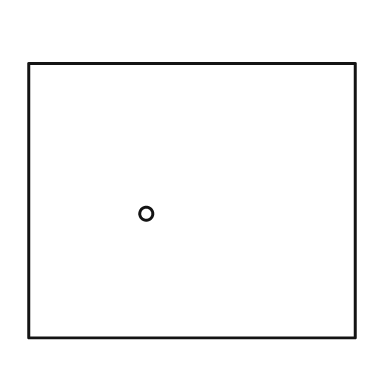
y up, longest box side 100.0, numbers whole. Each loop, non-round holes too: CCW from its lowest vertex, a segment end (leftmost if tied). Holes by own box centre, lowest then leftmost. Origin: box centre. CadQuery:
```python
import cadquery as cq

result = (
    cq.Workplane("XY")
    .moveTo(-50.0, -42.0)
    .lineTo(50.0, -42.0)
    .lineTo(50.0, 42.0)
    .lineTo(-50.0, 42.0)
    .close()
    .moveTo(-14.0, -4.0)
    .circle(2.0)
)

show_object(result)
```